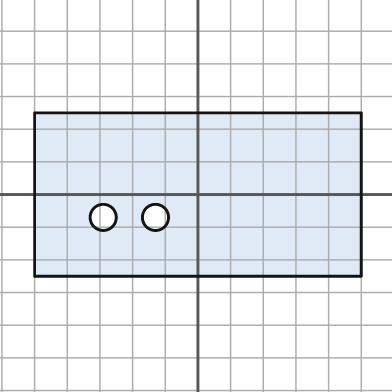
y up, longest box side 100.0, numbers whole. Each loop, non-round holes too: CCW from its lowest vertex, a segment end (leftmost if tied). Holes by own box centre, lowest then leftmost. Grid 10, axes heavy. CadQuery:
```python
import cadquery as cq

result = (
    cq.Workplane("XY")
    .moveTo(-50.0, -25.0)
    .lineTo(50.0, -25.0)
    .lineTo(50.0, 25.0)
    .lineTo(-50.0, 25.0)
    .close()
    .moveTo(-29.0, -7.0)
    .circle(4.0)
    .moveTo(-13.0, -7.0)
    .circle(4.0)
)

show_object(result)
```